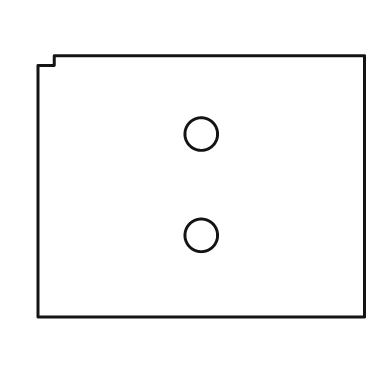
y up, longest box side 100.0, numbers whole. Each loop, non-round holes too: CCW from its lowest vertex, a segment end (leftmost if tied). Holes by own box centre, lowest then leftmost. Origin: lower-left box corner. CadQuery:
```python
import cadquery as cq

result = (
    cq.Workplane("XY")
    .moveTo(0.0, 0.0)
    .lineTo(100.0, 0.0)
    .lineTo(100.0, 80.0)
    .lineTo(5.0, 80.0)
    .lineTo(5.0, 77.0)
    .lineTo(0.0, 77.0)
    .close()
    .moveTo(50.0, 25.0)
    .circle(5.0)
    .moveTo(50.0, 56.0)
    .circle(5.0)
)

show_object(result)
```